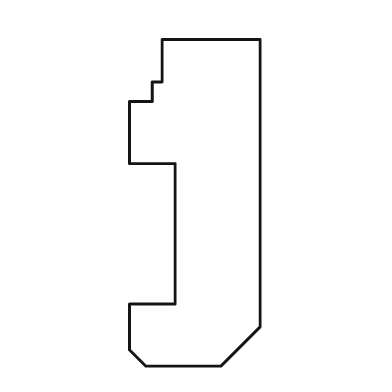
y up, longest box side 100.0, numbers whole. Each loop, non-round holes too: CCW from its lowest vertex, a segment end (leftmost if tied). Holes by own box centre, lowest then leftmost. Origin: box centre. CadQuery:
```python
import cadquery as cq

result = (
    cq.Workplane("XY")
    .moveTo(-15.0, -50.0)
    .lineTo(8.0, -50.0)
    .lineTo(20.0, -38.0)
    .lineTo(20.0, 50.0)
    .lineTo(-10.0, 50.0)
    .lineTo(-10.0, 37.0)
    .lineTo(-13.0, 37.0)
    .lineTo(-13.0, 31.0)
    .lineTo(-20.0, 31.0)
    .lineTo(-20.0, 12.0)
    .lineTo(-6.0, 12.0)
    .lineTo(-6.0, -31.0)
    .lineTo(-20.0, -31.0)
    .lineTo(-20.0, -45.0)
    .close()
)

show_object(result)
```